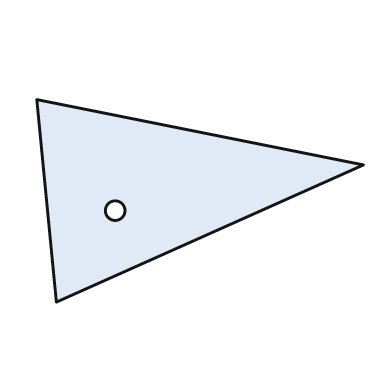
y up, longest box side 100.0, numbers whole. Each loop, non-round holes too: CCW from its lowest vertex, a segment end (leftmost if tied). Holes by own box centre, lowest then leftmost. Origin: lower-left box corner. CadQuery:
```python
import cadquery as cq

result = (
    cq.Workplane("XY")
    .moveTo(6.0, 0.0)
    .lineTo(100.0, 42.0)
    .lineTo(0.0, 62.0)
    .close()
    .moveTo(24.0, 28.0)
    .circle(3.0)
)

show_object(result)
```